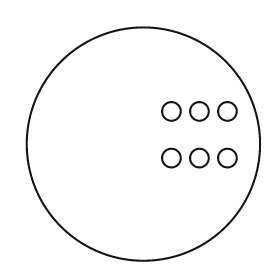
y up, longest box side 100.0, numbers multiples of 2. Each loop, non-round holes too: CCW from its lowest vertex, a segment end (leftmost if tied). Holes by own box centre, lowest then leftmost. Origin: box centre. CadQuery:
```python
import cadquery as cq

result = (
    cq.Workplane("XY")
    .moveTo(0.0, 0.0)
    .circle(50.0)
    .moveTo(12.0, -6.0)
    .circle(4.0)
    .moveTo(24.0, -6.0)
    .circle(4.0)
    .moveTo(36.0, -6.0)
    .circle(4.0)
    .moveTo(12.0, 14.0)
    .circle(4.0)
    .moveTo(24.0, 14.0)
    .circle(4.0)
    .moveTo(36.0, 14.0)
    .circle(4.0)
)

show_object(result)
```